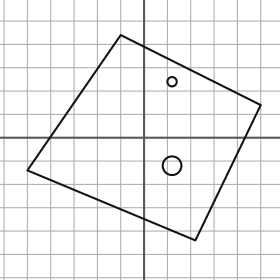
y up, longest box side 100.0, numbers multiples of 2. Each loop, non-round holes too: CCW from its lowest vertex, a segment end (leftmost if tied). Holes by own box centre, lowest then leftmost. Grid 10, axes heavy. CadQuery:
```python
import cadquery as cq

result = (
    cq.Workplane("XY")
    .moveTo(22.0, -44.0)
    .lineTo(50.0, 14.0)
    .lineTo(-10.0, 44.0)
    .lineTo(-50.0, -14.0)
    .close()
    .moveTo(12.0, -12.0)
    .circle(4.0)
    .moveTo(12.0, 24.0)
    .circle(2.0)
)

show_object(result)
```